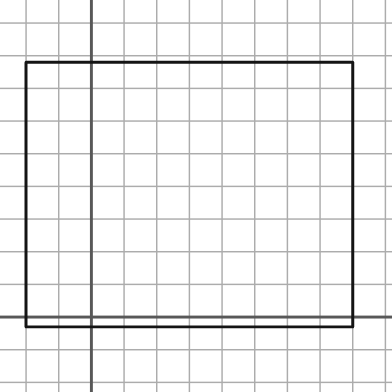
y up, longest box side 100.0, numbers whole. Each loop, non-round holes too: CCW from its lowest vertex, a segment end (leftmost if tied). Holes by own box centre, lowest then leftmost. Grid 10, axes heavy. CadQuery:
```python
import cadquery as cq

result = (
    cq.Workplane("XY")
    .moveTo(-20.0, -3.0)
    .lineTo(80.0, -3.0)
    .lineTo(80.0, 78.0)
    .lineTo(-20.0, 78.0)
    .close()
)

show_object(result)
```